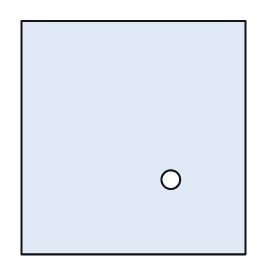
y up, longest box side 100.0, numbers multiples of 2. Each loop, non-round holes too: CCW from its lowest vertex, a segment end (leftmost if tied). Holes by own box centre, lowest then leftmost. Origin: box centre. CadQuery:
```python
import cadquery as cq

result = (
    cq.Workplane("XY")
    .moveTo(-48.0, -50.0)
    .lineTo(48.0, -50.0)
    .lineTo(48.0, 50.0)
    .lineTo(-48.0, 50.0)
    .close()
    .moveTo(16.0, -18.0)
    .circle(4.0)
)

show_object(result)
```